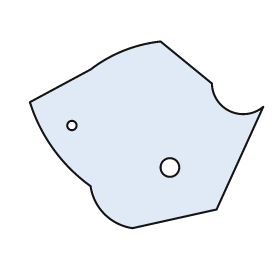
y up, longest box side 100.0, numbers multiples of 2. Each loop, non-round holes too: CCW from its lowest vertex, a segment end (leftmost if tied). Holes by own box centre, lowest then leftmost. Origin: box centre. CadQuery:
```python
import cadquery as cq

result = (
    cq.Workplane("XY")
    .moveTo(-6.0, -40.0)
    .lineTo(30.0, -32.0)
    .lineTo(50.0, 12.0)
    .threePointArc((36.0, 10.0), (28.0, 22.0))
    .lineTo(6.0, 40.0)
    .threePointArc((-10.0, 36.0), (-24.0, 28.0))
    .lineTo(-50.0, 14.0)
    .threePointArc((-40.0, -6.0), (-24.0, -22.0))
    .threePointArc((-18.0, -34.0), (-6.0, -40.0))
    .close()
    .moveTo(10.0, -14.0)
    .circle(4.0)
    .moveTo(-32.0, 4.0)
    .circle(2.0)
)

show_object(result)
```